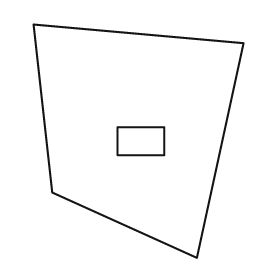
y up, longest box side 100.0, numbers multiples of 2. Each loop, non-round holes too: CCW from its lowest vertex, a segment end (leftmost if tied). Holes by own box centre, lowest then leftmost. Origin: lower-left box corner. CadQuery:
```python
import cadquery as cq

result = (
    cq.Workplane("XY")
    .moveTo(70.0, 0.0)
    .lineTo(90.0, 92.0)
    .lineTo(0.0, 100.0)
    .lineTo(8.0, 28.0)
    .close()
    .moveTo(36.0, 44.0)
    .lineTo(56.0, 44.0)
    .lineTo(56.0, 56.0)
    .lineTo(36.0, 56.0)
    .close()
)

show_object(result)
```